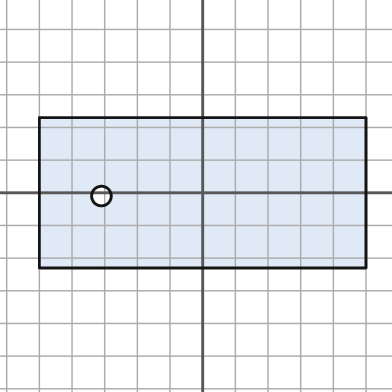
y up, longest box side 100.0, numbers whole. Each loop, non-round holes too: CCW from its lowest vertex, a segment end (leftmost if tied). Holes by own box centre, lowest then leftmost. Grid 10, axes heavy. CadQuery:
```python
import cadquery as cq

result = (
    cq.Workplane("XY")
    .moveTo(-50.0, -23.0)
    .lineTo(50.0, -23.0)
    .lineTo(50.0, 23.0)
    .lineTo(-50.0, 23.0)
    .close()
    .moveTo(-31.0, -1.0)
    .circle(3.0)
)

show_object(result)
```